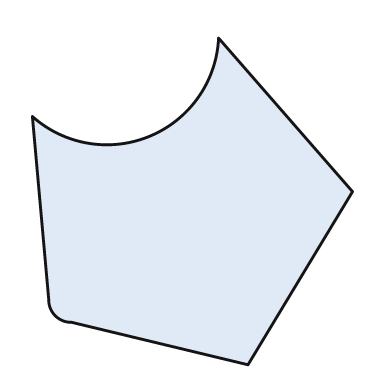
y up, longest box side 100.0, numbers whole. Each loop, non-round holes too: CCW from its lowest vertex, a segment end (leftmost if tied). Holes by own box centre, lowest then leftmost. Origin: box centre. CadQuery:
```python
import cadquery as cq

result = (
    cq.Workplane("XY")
    .moveTo(17.0, -50.0)
    .lineTo(49.0, 3.0)
    .lineTo(8.0, 50.0)
    .threePointArc((-13.0, 20.0), (-49.0, 26.0))
    .lineTo(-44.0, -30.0)
    .threePointArc((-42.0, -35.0), (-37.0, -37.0))
    .close()
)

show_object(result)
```